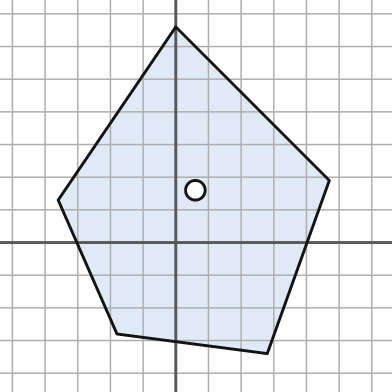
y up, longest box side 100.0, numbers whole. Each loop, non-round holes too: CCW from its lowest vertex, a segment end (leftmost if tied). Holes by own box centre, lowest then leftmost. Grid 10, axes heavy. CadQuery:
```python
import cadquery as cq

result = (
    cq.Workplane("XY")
    .moveTo(28.0, -34.0)
    .lineTo(47.0, 19.0)
    .lineTo(0.0, 66.0)
    .lineTo(-36.0, 13.0)
    .lineTo(-18.0, -28.0)
    .close()
    .moveTo(6.0, 16.0)
    .circle(3.0)
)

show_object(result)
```